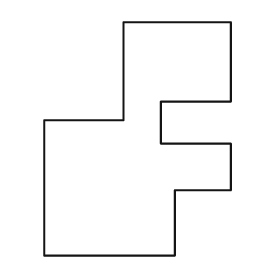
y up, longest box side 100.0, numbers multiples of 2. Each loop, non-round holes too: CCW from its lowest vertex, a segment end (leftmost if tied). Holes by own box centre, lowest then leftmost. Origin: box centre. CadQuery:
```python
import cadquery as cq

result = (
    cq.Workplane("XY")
    .moveTo(-40.0, -50.0)
    .lineTo(16.0, -50.0)
    .lineTo(16.0, -22.0)
    .lineTo(40.0, -22.0)
    .lineTo(40.0, -2.0)
    .lineTo(10.0, -2.0)
    .lineTo(10.0, 16.0)
    .lineTo(40.0, 16.0)
    .lineTo(40.0, 50.0)
    .lineTo(-6.0, 50.0)
    .lineTo(-6.0, 8.0)
    .lineTo(-40.0, 8.0)
    .close()
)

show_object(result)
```